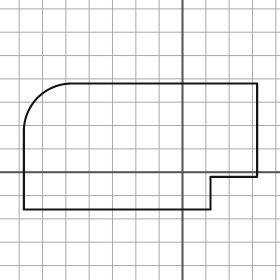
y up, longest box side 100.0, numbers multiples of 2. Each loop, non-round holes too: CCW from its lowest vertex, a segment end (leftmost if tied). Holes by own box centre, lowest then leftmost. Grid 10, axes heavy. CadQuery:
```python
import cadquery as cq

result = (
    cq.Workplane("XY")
    .moveTo(-68.0, -16.0)
    .lineTo(12.0, -16.0)
    .lineTo(12.0, -2.0)
    .lineTo(32.0, -2.0)
    .lineTo(32.0, 38.0)
    .lineTo(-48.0, 38.0)
    .threePointArc((-62.0, 32.0), (-68.0, 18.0))
    .close()
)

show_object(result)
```